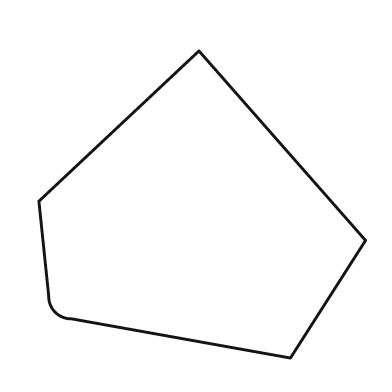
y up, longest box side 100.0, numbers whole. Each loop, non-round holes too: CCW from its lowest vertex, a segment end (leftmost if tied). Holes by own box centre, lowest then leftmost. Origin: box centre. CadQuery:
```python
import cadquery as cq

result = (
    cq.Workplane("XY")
    .moveTo(27.0, -47.0)
    .lineTo(50.0, -11.0)
    .lineTo(-1.0, 47.0)
    .lineTo(-50.0, 1.0)
    .lineTo(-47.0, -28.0)
    .threePointArc((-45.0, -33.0), (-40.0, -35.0))
    .close()
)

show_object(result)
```